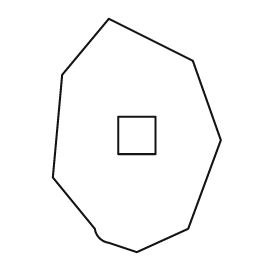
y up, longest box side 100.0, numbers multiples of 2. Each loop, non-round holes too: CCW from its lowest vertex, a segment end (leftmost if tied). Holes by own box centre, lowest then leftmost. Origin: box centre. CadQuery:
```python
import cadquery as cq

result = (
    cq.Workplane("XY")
    .moveTo(0.0, -50.0)
    .lineTo(22.0, -40.0)
    .lineTo(36.0, -2.0)
    .lineTo(24.0, 32.0)
    .lineTo(-12.0, 50.0)
    .lineTo(-32.0, 26.0)
    .lineTo(-36.0, -18.0)
    .lineTo(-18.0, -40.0)
    .threePointArc((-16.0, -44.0), (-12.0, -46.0))
    .close()
    .moveTo(-8.0, -8.0)
    .lineTo(8.0, -8.0)
    .lineTo(8.0, 8.0)
    .lineTo(-8.0, 8.0)
    .close()
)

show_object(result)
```